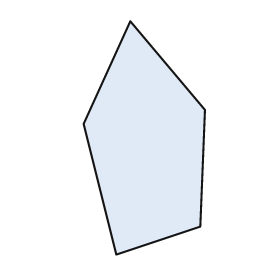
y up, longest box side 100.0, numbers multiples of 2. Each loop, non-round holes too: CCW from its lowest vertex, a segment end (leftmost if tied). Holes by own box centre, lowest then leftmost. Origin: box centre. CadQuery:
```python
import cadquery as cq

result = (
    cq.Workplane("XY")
    .moveTo(-12.0, -50.0)
    .lineTo(24.0, -38.0)
    .lineTo(26.0, 12.0)
    .lineTo(-6.0, 50.0)
    .lineTo(-26.0, 6.0)
    .close()
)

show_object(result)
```